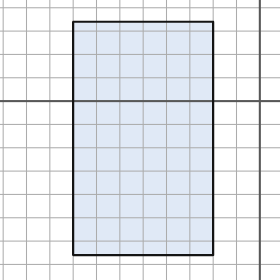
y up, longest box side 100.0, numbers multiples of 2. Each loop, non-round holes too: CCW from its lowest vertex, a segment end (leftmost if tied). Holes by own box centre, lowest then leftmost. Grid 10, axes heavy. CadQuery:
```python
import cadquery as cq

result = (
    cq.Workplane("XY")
    .moveTo(-80.0, -66.0)
    .lineTo(-20.0, -66.0)
    .lineTo(-20.0, 34.0)
    .lineTo(-80.0, 34.0)
    .close()
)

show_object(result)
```